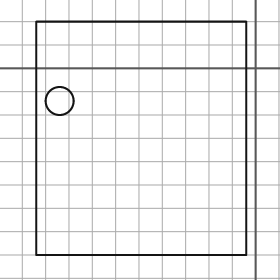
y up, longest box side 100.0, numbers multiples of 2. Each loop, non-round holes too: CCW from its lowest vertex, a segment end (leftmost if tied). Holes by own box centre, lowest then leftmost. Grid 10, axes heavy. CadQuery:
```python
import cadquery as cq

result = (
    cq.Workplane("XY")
    .moveTo(-94.0, -80.0)
    .lineTo(-4.0, -80.0)
    .lineTo(-4.0, 20.0)
    .lineTo(-94.0, 20.0)
    .close()
    .moveTo(-84.0, -14.0)
    .circle(6.0)
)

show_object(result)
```